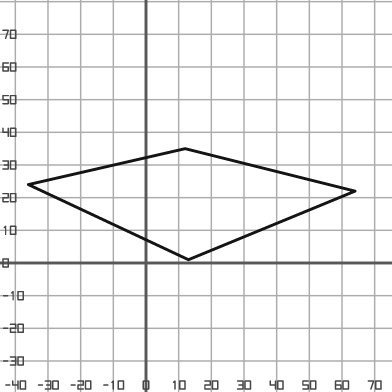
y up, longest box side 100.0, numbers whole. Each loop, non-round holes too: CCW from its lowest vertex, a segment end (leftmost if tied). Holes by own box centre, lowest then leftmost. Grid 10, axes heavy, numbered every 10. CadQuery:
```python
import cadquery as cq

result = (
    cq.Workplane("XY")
    .moveTo(13.0, 1.0)
    .lineTo(64.0, 22.0)
    .lineTo(12.0, 35.0)
    .lineTo(-36.0, 24.0)
    .close()
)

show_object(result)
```